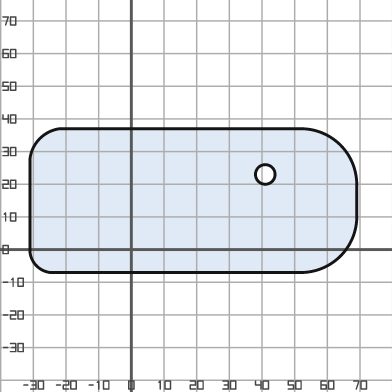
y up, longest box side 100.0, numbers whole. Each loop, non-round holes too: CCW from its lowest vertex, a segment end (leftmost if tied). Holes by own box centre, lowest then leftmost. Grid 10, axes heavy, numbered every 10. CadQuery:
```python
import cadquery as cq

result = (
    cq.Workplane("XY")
    .moveTo(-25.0, -7.0)
    .lineTo(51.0, -7.0)
    .threePointArc((64.0, -2.0), (69.0, 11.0))
    .lineTo(69.0, 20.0)
    .threePointArc((64.0, 32.0), (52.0, 37.0))
    .lineTo(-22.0, 37.0)
    .threePointArc((-28.0, 34.0), (-31.0, 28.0))
    .lineTo(-31.0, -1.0)
    .threePointArc((-29.0, -5.0), (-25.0, -7.0))
    .close()
    .moveTo(41.0, 23.0)
    .circle(3.0)
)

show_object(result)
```